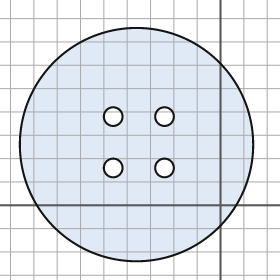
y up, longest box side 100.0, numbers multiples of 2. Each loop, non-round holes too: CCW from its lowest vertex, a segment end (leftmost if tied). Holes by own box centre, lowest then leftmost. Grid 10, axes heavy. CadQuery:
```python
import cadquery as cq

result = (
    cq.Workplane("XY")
    .moveTo(-36.0, 26.0)
    .circle(50.0)
    .moveTo(-46.0, 16.0)
    .circle(4.0)
    .moveTo(-24.0, 16.0)
    .circle(4.0)
    .moveTo(-46.0, 38.0)
    .circle(4.0)
    .moveTo(-24.0, 38.0)
    .circle(4.0)
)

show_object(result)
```